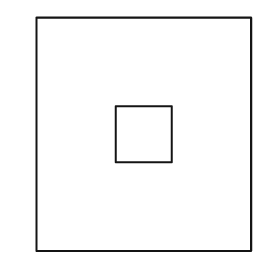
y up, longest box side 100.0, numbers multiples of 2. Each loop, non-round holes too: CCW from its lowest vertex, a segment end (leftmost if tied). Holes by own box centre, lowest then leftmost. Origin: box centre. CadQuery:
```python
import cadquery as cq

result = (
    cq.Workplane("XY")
    .moveTo(-46.0, -50.0)
    .lineTo(46.0, -50.0)
    .lineTo(46.0, 50.0)
    .lineTo(-46.0, 50.0)
    .close()
    .moveTo(-12.0, -12.0)
    .lineTo(12.0, -12.0)
    .lineTo(12.0, 12.0)
    .lineTo(-12.0, 12.0)
    .close()
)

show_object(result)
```